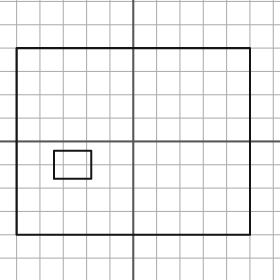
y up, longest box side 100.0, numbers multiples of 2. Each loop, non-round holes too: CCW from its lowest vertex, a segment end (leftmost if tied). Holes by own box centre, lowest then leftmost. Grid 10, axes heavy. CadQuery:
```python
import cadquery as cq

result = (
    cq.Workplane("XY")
    .moveTo(-50.0, -40.0)
    .lineTo(50.0, -40.0)
    .lineTo(50.0, 40.0)
    .lineTo(-50.0, 40.0)
    .close()
    .moveTo(-34.0, -16.0)
    .lineTo(-18.0, -16.0)
    .lineTo(-18.0, -4.0)
    .lineTo(-34.0, -4.0)
    .close()
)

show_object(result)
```